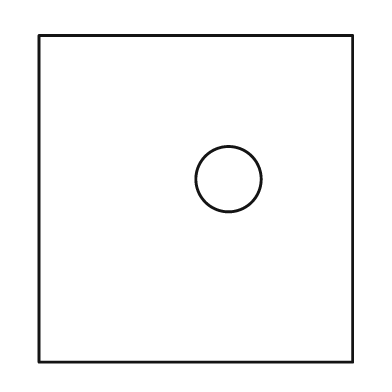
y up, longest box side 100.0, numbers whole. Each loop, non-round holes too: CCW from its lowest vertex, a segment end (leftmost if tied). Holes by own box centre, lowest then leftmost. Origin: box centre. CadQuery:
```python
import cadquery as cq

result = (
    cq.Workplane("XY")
    .moveTo(-48.0, -50.0)
    .lineTo(48.0, -50.0)
    .lineTo(48.0, 50.0)
    .lineTo(-48.0, 50.0)
    .close()
    .moveTo(10.0, 6.0)
    .circle(10.0)
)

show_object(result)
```